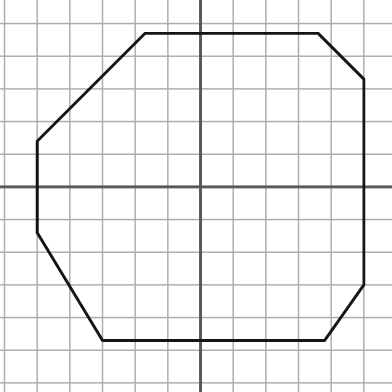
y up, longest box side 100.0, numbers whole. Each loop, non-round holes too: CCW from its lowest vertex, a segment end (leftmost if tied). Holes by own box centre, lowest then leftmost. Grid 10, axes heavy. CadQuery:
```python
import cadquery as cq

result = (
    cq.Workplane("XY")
    .moveTo(-30.0, -47.0)
    .lineTo(38.0, -47.0)
    .lineTo(50.0, -30.0)
    .lineTo(50.0, 33.0)
    .lineTo(36.0, 47.0)
    .lineTo(-17.0, 47.0)
    .lineTo(-50.0, 14.0)
    .lineTo(-50.0, -14.0)
    .close()
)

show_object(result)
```